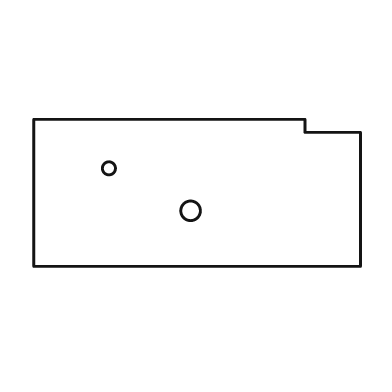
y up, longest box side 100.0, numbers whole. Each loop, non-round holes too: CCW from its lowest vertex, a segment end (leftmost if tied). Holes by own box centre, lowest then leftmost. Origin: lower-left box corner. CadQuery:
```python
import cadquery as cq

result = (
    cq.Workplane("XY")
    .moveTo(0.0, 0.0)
    .lineTo(100.0, 0.0)
    .lineTo(100.0, 41.0)
    .lineTo(83.0, 41.0)
    .lineTo(83.0, 45.0)
    .lineTo(0.0, 45.0)
    .close()
    .moveTo(48.0, 17.0)
    .circle(3.0)
    .moveTo(23.0, 30.0)
    .circle(2.0)
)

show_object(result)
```